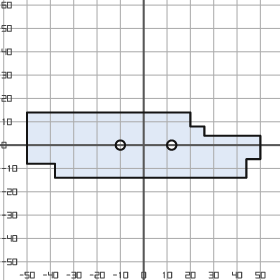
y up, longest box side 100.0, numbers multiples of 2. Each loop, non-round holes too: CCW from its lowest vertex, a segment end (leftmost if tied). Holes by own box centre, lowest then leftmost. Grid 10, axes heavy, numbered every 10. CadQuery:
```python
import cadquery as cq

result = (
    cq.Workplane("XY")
    .moveTo(-38.0, -14.0)
    .lineTo(44.0, -14.0)
    .lineTo(44.0, -6.0)
    .lineTo(50.0, -6.0)
    .lineTo(50.0, 4.0)
    .lineTo(26.0, 4.0)
    .lineTo(26.0, 8.0)
    .lineTo(20.0, 8.0)
    .lineTo(20.0, 14.0)
    .lineTo(-50.0, 14.0)
    .lineTo(-50.0, -8.0)
    .lineTo(-38.0, -8.0)
    .close()
    .moveTo(-10.0, 0.0)
    .circle(2.0)
    .moveTo(12.0, 0.0)
    .circle(2.0)
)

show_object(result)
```